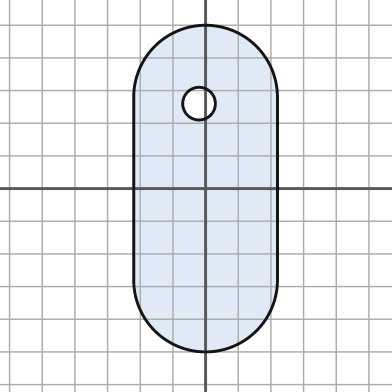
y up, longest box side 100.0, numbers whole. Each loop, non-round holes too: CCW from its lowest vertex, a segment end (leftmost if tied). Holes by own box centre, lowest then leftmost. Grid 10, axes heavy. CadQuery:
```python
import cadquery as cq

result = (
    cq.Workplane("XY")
    .moveTo(-22.0, -28.0)
    .threePointArc((0.0, -50.0), (22.0, -28.0))
    .lineTo(22.0, 28.0)
    .threePointArc((0.0, 50.0), (-22.0, 28.0))
    .close()
    .moveTo(-2.0, 26.0)
    .circle(5.0)
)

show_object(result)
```